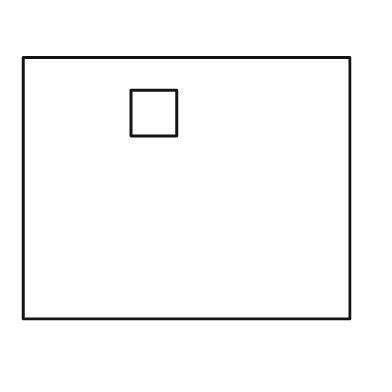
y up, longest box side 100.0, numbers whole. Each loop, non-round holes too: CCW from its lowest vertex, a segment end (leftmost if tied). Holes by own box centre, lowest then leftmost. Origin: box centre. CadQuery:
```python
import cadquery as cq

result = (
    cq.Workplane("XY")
    .moveTo(-50.0, -40.0)
    .lineTo(50.0, -40.0)
    .lineTo(50.0, 40.0)
    .lineTo(-50.0, 40.0)
    .close()
    .moveTo(-17.0, 16.0)
    .lineTo(-3.0, 16.0)
    .lineTo(-3.0, 30.0)
    .lineTo(-17.0, 30.0)
    .close()
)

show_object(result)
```